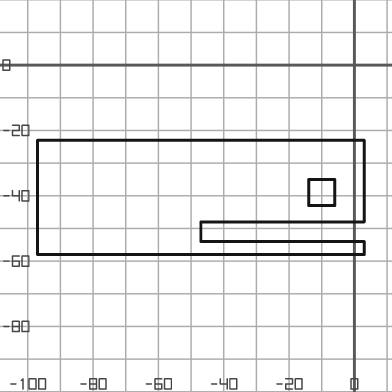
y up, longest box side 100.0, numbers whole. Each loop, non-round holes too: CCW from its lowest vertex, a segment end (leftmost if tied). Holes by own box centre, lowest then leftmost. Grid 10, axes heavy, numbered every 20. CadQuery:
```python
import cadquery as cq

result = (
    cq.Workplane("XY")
    .moveTo(-97.0, -58.0)
    .lineTo(3.0, -58.0)
    .lineTo(3.0, -54.0)
    .lineTo(-47.0, -54.0)
    .lineTo(-47.0, -48.0)
    .lineTo(3.0, -48.0)
    .lineTo(3.0, -23.0)
    .lineTo(-97.0, -23.0)
    .close()
    .moveTo(-14.0, -43.0)
    .lineTo(-6.0, -43.0)
    .lineTo(-6.0, -35.0)
    .lineTo(-14.0, -35.0)
    .close()
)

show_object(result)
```